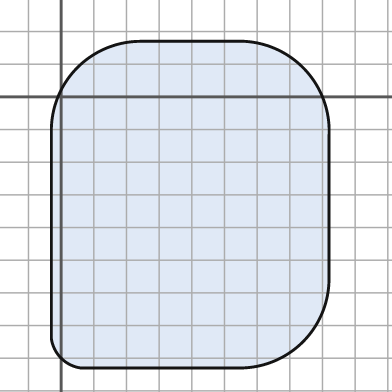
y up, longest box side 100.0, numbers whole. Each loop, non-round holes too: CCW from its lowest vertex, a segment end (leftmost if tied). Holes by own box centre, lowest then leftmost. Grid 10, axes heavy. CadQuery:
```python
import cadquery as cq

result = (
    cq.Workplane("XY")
    .moveTo(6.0, -83.0)
    .lineTo(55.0, -83.0)
    .threePointArc((74.0, -75.0), (82.0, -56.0))
    .lineTo(82.0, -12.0)
    .threePointArc((74.0, 9.0), (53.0, 17.0))
    .lineTo(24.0, 17.0)
    .threePointArc((5.0, 9.0), (-3.0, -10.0))
    .lineTo(-3.0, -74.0)
    .threePointArc((0.0, -80.0), (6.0, -83.0))
    .close()
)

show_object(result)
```